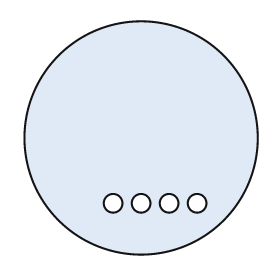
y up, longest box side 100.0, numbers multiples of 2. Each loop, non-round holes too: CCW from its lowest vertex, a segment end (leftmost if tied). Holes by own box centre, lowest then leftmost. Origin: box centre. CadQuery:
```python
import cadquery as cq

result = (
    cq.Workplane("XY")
    .moveTo(0.0, 0.0)
    .circle(50.0)
    .moveTo(-12.0, -28.0)
    .circle(4.0)
    .moveTo(0.0, -28.0)
    .circle(4.0)
    .moveTo(12.0, -28.0)
    .circle(4.0)
    .moveTo(24.0, -28.0)
    .circle(4.0)
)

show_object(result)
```